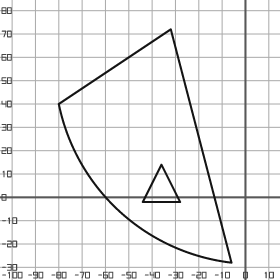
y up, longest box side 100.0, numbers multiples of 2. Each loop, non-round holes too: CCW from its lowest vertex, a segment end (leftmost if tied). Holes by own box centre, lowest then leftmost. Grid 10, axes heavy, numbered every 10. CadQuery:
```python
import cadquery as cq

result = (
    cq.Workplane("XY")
    .moveTo(-6.0, -28.0)
    .lineTo(-32.0, 72.0)
    .lineTo(-80.0, 40.0)
    .threePointArc((-54.0, -6.0), (-6.0, -28.0))
    .close()
    .moveTo(-44.0, -2.0)
    .lineTo(-28.0, -2.0)
    .lineTo(-36.0, 14.0)
    .close()
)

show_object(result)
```